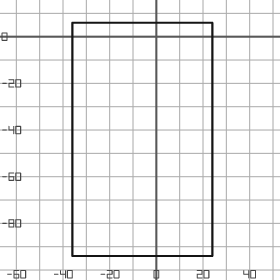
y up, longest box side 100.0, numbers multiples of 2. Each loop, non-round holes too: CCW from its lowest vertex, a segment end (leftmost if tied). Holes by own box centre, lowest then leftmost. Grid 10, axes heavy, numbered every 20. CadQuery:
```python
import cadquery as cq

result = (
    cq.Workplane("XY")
    .moveTo(-36.0, -94.0)
    .lineTo(24.0, -94.0)
    .lineTo(24.0, 6.0)
    .lineTo(-36.0, 6.0)
    .close()
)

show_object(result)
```